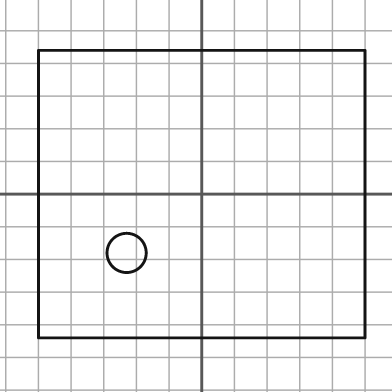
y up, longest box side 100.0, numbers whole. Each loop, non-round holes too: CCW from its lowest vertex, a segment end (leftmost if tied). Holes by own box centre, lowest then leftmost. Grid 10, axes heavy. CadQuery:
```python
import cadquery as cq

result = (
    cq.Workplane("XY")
    .moveTo(-50.0, -44.0)
    .lineTo(50.0, -44.0)
    .lineTo(50.0, 44.0)
    .lineTo(-50.0, 44.0)
    .close()
    .moveTo(-23.0, -18.0)
    .circle(6.0)
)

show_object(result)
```